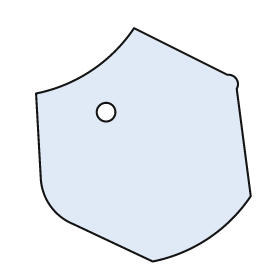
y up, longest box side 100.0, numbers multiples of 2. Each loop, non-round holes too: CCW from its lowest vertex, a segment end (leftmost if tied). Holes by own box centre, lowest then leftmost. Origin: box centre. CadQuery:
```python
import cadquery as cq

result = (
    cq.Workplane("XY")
    .moveTo(4.0, -50.0)
    .threePointArc((28.0, -40.0), (46.0, -22.0))
    .lineTo(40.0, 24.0)
    .threePointArc((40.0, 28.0), (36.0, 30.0))
    .lineTo(-4.0, 50.0)
    .threePointArc((-22.0, 32.0), (-46.0, 22.0))
    .lineTo(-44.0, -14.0)
    .threePointArc((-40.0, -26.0), (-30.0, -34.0))
    .close()
    .moveTo(-16.0, 14.0)
    .circle(4.0)
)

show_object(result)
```